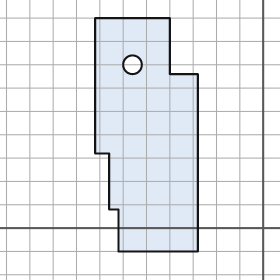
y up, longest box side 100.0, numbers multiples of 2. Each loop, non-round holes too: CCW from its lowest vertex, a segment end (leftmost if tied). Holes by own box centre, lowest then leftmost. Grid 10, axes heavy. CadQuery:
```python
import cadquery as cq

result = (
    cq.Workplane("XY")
    .moveTo(-62.0, -10.0)
    .lineTo(-28.0, -10.0)
    .lineTo(-28.0, 66.0)
    .lineTo(-40.0, 66.0)
    .lineTo(-40.0, 90.0)
    .lineTo(-72.0, 90.0)
    .lineTo(-72.0, 32.0)
    .lineTo(-66.0, 32.0)
    .lineTo(-66.0, 8.0)
    .lineTo(-62.0, 8.0)
    .close()
    .moveTo(-56.0, 70.0)
    .circle(4.0)
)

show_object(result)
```